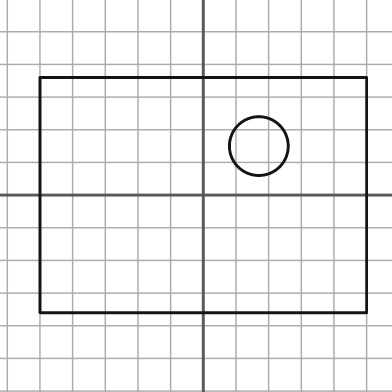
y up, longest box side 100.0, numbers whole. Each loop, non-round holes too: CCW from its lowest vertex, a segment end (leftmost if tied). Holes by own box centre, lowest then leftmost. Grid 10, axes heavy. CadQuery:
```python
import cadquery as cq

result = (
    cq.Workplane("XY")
    .moveTo(-50.0, -36.0)
    .lineTo(50.0, -36.0)
    .lineTo(50.0, 36.0)
    .lineTo(-50.0, 36.0)
    .close()
    .moveTo(17.0, 15.0)
    .circle(9.0)
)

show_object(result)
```